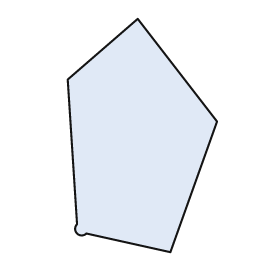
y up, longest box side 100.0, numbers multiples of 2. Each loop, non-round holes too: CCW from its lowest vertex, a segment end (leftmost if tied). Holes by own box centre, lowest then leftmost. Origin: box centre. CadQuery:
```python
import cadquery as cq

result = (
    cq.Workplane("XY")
    .moveTo(12.0, -50.0)
    .lineTo(32.0, 6.0)
    .lineTo(-2.0, 50.0)
    .lineTo(-32.0, 24.0)
    .lineTo(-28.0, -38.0)
    .threePointArc((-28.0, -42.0), (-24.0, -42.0))
    .close()
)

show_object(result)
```